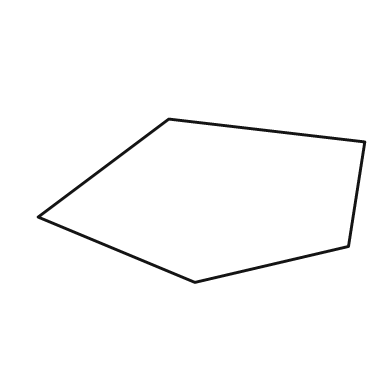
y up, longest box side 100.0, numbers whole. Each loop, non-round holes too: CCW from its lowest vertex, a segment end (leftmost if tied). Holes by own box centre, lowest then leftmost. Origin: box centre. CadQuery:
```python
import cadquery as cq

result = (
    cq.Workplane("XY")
    .moveTo(-2.0, -25.0)
    .lineTo(45.0, -14.0)
    .lineTo(50.0, 18.0)
    .lineTo(-10.0, 25.0)
    .lineTo(-50.0, -5.0)
    .close()
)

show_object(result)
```